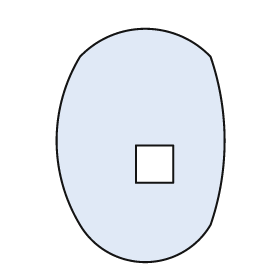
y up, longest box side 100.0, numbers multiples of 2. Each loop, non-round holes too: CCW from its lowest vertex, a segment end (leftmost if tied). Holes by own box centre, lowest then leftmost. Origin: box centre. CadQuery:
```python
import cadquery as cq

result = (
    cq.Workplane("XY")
    .moveTo(-26.0, -34.0)
    .threePointArc((2.0, -50.0), (30.0, -34.0))
    .threePointArc((36.0, 2.0), (30.0, 38.0))
    .threePointArc((2.0, 50.0), (-26.0, 38.0))
    .threePointArc((-36.0, 2.0), (-26.0, -34.0))
    .close()
    .moveTo(-2.0, -16.0)
    .lineTo(14.0, -16.0)
    .lineTo(14.0, 0.0)
    .lineTo(-2.0, 0.0)
    .close()
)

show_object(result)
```